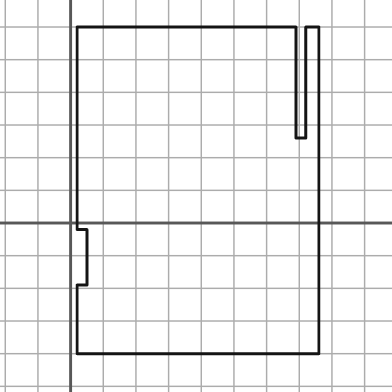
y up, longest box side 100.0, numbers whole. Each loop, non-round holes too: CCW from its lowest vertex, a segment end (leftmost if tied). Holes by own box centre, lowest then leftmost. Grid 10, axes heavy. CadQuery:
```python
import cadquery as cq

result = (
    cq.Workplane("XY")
    .moveTo(2.0, -40.0)
    .lineTo(76.0, -40.0)
    .lineTo(76.0, 60.0)
    .lineTo(72.0, 60.0)
    .lineTo(72.0, 26.0)
    .lineTo(69.0, 26.0)
    .lineTo(69.0, 60.0)
    .lineTo(2.0, 60.0)
    .lineTo(2.0, -2.0)
    .lineTo(5.0, -2.0)
    .lineTo(5.0, -19.0)
    .lineTo(2.0, -19.0)
    .close()
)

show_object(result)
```